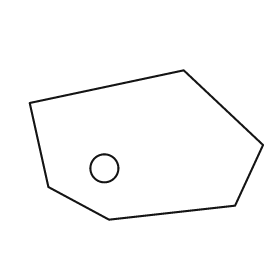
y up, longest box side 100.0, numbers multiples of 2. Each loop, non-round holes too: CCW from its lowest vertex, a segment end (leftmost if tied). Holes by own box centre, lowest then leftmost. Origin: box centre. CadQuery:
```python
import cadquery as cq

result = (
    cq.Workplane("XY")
    .moveTo(-16.0, -32.0)
    .lineTo(38.0, -26.0)
    .lineTo(50.0, 0.0)
    .lineTo(16.0, 32.0)
    .lineTo(-50.0, 18.0)
    .lineTo(-42.0, -18.0)
    .close()
    .moveTo(-18.0, -10.0)
    .circle(6.0)
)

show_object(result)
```